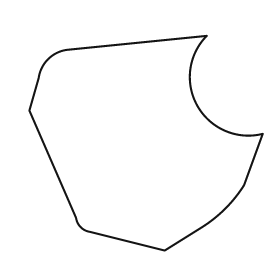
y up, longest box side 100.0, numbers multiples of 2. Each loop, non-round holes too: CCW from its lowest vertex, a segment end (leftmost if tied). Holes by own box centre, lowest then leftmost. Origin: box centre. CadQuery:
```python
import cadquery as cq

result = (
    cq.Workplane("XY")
    .moveTo(8.0, -46.0)
    .lineTo(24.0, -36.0)
    .threePointArc((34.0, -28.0), (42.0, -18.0))
    .lineTo(50.0, 4.0)
    .threePointArc((22.0, 16.0), (26.0, 46.0))
    .lineTo(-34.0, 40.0)
    .threePointArc((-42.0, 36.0), (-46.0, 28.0))
    .lineTo(-50.0, 14.0)
    .lineTo(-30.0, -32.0)
    .threePointArc((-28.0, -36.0), (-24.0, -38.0))
    .close()
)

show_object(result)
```